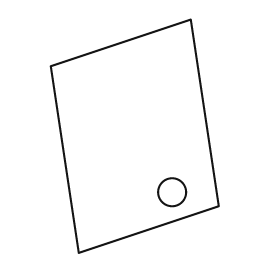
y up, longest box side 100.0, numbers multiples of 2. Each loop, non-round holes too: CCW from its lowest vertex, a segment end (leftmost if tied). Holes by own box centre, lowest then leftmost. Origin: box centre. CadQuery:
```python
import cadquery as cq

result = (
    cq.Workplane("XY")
    .moveTo(-24.0, -50.0)
    .lineTo(36.0, -30.0)
    .lineTo(24.0, 50.0)
    .lineTo(-36.0, 30.0)
    .close()
    .moveTo(16.0, -24.0)
    .circle(6.0)
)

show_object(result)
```